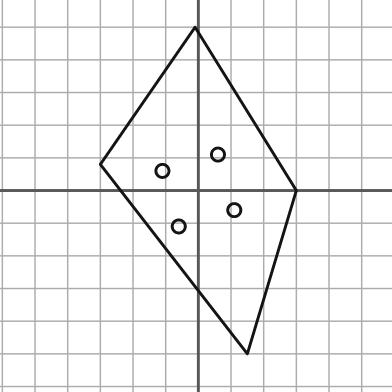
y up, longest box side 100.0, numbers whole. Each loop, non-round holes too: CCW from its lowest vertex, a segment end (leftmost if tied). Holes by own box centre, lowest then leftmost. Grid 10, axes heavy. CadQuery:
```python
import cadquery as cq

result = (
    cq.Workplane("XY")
    .moveTo(15.0, -50.0)
    .lineTo(30.0, 0.0)
    .lineTo(-1.0, 50.0)
    .lineTo(-30.0, 8.0)
    .close()
    .moveTo(-6.0, -11.0)
    .circle(2.0)
    .moveTo(11.0, -6.0)
    .circle(2.0)
    .moveTo(-11.0, 6.0)
    .circle(2.0)
    .moveTo(6.0, 11.0)
    .circle(2.0)
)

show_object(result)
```